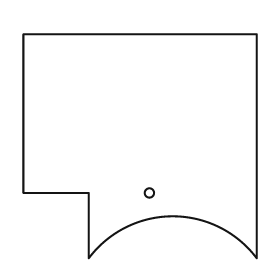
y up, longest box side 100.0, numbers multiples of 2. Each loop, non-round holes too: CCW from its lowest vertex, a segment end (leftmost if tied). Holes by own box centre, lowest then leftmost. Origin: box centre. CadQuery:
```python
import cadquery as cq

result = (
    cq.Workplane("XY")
    .moveTo(-22.0, -48.0)
    .threePointArc((14.0, -30.0), (50.0, -48.0))
    .lineTo(50.0, 48.0)
    .lineTo(-50.0, 48.0)
    .lineTo(-50.0, -20.0)
    .lineTo(-22.0, -20.0)
    .close()
    .moveTo(4.0, -20.0)
    .circle(2.0)
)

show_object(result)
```